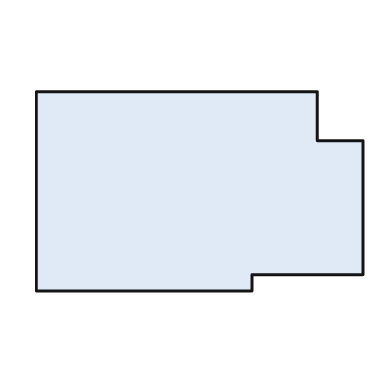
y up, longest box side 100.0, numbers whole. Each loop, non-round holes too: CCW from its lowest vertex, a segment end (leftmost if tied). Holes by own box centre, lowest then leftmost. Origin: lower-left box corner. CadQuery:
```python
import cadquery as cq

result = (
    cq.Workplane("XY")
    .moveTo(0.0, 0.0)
    .lineTo(66.0, 0.0)
    .lineTo(66.0, 5.0)
    .lineTo(100.0, 5.0)
    .lineTo(100.0, 46.0)
    .lineTo(86.0, 46.0)
    .lineTo(86.0, 61.0)
    .lineTo(0.0, 61.0)
    .close()
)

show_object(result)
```